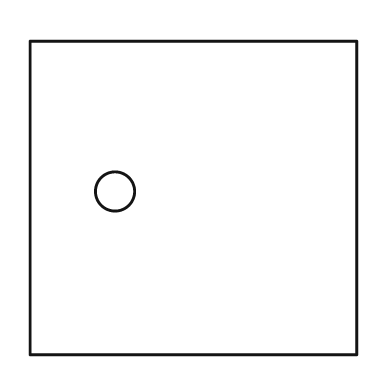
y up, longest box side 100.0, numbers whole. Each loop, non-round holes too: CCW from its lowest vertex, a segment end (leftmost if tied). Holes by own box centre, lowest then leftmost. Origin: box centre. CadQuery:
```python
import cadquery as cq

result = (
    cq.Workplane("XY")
    .moveTo(-50.0, -48.0)
    .lineTo(50.0, -48.0)
    .lineTo(50.0, 48.0)
    .lineTo(-50.0, 48.0)
    .close()
    .moveTo(-24.0, 2.0)
    .circle(6.0)
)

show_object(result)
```